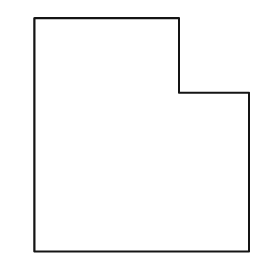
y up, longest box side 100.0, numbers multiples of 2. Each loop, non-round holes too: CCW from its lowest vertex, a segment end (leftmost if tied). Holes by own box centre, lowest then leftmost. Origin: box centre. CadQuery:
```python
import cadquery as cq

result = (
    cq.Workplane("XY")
    .moveTo(-46.0, -50.0)
    .lineTo(46.0, -50.0)
    .lineTo(46.0, 18.0)
    .lineTo(16.0, 18.0)
    .lineTo(16.0, 50.0)
    .lineTo(-46.0, 50.0)
    .close()
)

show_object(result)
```